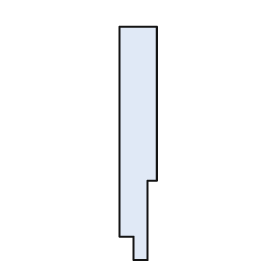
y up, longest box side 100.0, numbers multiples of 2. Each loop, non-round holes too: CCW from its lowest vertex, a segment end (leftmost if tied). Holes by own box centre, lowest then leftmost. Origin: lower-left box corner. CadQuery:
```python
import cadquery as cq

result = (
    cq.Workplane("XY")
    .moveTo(6.0, 0.0)
    .lineTo(12.0, 0.0)
    .lineTo(12.0, 34.0)
    .lineTo(16.0, 34.0)
    .lineTo(16.0, 100.0)
    .lineTo(0.0, 100.0)
    .lineTo(0.0, 10.0)
    .lineTo(6.0, 10.0)
    .close()
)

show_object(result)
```